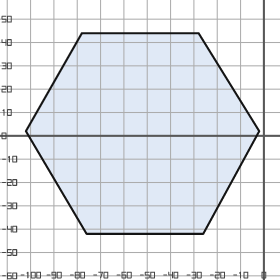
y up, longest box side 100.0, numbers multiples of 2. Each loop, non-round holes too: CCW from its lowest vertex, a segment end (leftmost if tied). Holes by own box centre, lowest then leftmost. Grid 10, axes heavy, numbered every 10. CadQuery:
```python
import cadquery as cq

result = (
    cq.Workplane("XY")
    .moveTo(-76.0, -42.0)
    .lineTo(-26.0, -42.0)
    .lineTo(-2.0, 2.0)
    .lineTo(-28.0, 44.0)
    .lineTo(-78.0, 44.0)
    .lineTo(-102.0, 2.0)
    .close()
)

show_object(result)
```